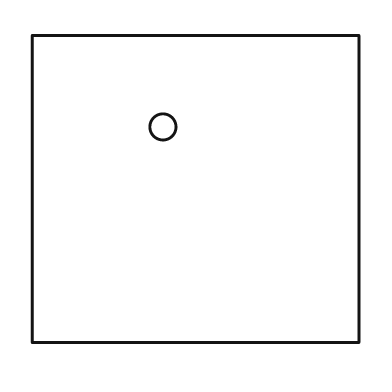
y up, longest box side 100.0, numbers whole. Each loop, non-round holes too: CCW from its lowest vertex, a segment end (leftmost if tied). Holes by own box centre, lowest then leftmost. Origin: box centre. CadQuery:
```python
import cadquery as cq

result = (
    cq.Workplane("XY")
    .moveTo(-50.0, -47.0)
    .lineTo(50.0, -47.0)
    .lineTo(50.0, 47.0)
    .lineTo(-50.0, 47.0)
    .close()
    .moveTo(-10.0, 19.0)
    .circle(4.0)
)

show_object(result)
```